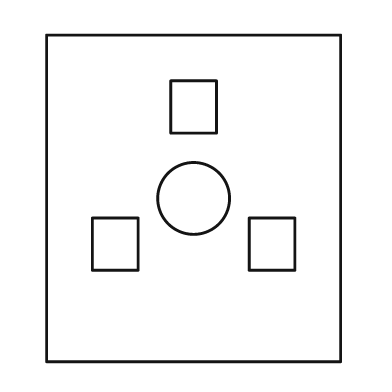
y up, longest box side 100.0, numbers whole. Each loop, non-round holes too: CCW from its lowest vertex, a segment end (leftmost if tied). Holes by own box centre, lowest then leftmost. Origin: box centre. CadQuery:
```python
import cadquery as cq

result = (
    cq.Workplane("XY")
    .moveTo(-45.0, -50.0)
    .lineTo(45.0, -50.0)
    .lineTo(45.0, 50.0)
    .lineTo(-45.0, 50.0)
    .close()
    .moveTo(-31.0, -22.0)
    .lineTo(-17.0, -22.0)
    .lineTo(-17.0, -6.0)
    .lineTo(-31.0, -6.0)
    .close()
    .moveTo(17.0, -22.0)
    .lineTo(31.0, -22.0)
    .lineTo(31.0, -6.0)
    .lineTo(17.0, -6.0)
    .close()
    .moveTo(0.0, 0.0)
    .circle(11.0)
    .moveTo(-7.0, 20.0)
    .lineTo(7.0, 20.0)
    .lineTo(7.0, 36.0)
    .lineTo(-7.0, 36.0)
    .close()
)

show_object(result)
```